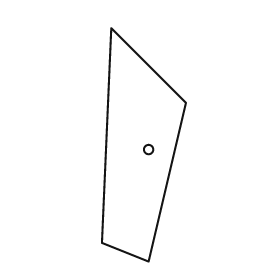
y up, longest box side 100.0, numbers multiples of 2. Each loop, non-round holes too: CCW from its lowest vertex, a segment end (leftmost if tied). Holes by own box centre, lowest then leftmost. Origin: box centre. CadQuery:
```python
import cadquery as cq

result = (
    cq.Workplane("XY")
    .moveTo(2.0, -50.0)
    .lineTo(18.0, 18.0)
    .lineTo(-14.0, 50.0)
    .lineTo(-18.0, -42.0)
    .close()
    .moveTo(2.0, -2.0)
    .circle(2.0)
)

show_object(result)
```